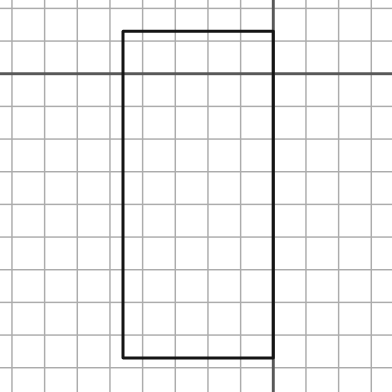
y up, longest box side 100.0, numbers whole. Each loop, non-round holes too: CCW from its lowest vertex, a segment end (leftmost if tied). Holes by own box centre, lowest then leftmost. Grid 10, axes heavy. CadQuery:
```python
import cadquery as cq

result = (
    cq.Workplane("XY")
    .moveTo(-46.0, -87.0)
    .lineTo(0.0, -87.0)
    .lineTo(0.0, 13.0)
    .lineTo(-46.0, 13.0)
    .close()
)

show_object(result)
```